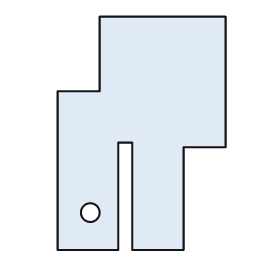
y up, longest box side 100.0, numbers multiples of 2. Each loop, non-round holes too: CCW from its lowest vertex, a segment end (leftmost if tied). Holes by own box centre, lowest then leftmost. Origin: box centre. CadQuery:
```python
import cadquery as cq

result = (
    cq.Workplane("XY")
    .moveTo(-36.0, -50.0)
    .lineTo(-10.0, -50.0)
    .lineTo(-10.0, -4.0)
    .lineTo(-4.0, -4.0)
    .lineTo(-4.0, -50.0)
    .lineTo(18.0, -50.0)
    .lineTo(18.0, -6.0)
    .lineTo(36.0, -6.0)
    .lineTo(36.0, 50.0)
    .lineTo(-18.0, 50.0)
    .lineTo(-18.0, 18.0)
    .lineTo(-36.0, 18.0)
    .close()
    .moveTo(-22.0, -34.0)
    .circle(4.0)
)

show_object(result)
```